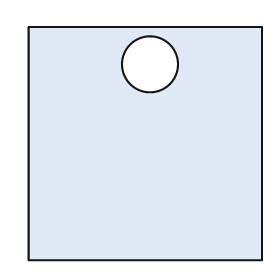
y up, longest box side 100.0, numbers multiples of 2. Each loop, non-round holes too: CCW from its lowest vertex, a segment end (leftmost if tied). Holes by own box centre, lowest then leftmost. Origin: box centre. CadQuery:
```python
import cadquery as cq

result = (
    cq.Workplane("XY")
    .moveTo(-50.0, -50.0)
    .lineTo(50.0, -50.0)
    .lineTo(50.0, 50.0)
    .lineTo(-50.0, 50.0)
    .close()
    .moveTo(2.0, 34.0)
    .circle(12.0)
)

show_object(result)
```